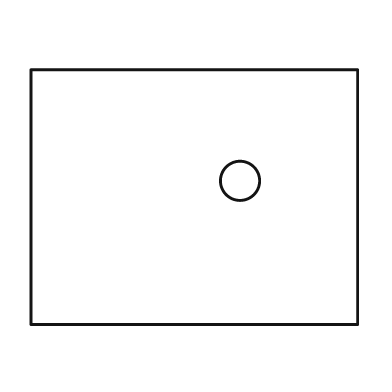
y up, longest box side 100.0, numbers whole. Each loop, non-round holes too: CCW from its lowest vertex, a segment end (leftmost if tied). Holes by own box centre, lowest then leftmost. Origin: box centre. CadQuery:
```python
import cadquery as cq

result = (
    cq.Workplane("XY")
    .moveTo(-50.0, -39.0)
    .lineTo(50.0, -39.0)
    .lineTo(50.0, 39.0)
    .lineTo(-50.0, 39.0)
    .close()
    .moveTo(14.0, 5.0)
    .circle(6.0)
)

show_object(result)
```